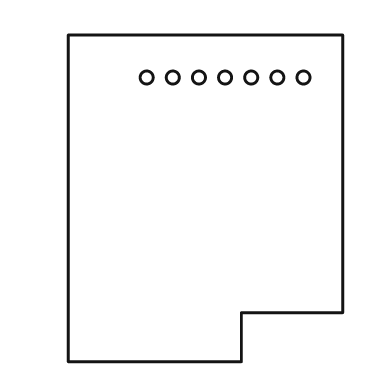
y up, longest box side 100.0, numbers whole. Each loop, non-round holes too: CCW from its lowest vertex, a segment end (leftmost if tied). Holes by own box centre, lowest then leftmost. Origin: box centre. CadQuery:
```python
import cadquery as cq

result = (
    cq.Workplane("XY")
    .moveTo(-42.0, -50.0)
    .lineTo(11.0, -50.0)
    .lineTo(11.0, -35.0)
    .lineTo(42.0, -35.0)
    .lineTo(42.0, 50.0)
    .lineTo(-42.0, 50.0)
    .close()
    .moveTo(-18.0, 37.0)
    .circle(2.0)
    .moveTo(-10.0, 37.0)
    .circle(2.0)
    .moveTo(-2.0, 37.0)
    .circle(2.0)
    .moveTo(6.0, 37.0)
    .circle(2.0)
    .moveTo(14.0, 37.0)
    .circle(2.0)
    .moveTo(22.0, 37.0)
    .circle(2.0)
    .moveTo(30.0, 37.0)
    .circle(2.0)
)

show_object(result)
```